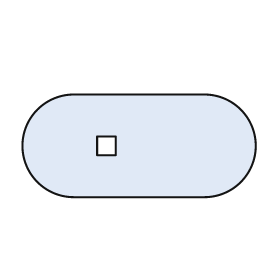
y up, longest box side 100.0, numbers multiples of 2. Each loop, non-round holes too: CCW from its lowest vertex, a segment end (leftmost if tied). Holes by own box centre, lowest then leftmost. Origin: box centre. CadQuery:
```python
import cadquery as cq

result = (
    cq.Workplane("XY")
    .moveTo(-28.0, -22.0)
    .lineTo(28.0, -22.0)
    .threePointArc((50.0, 0.0), (28.0, 22.0))
    .lineTo(-28.0, 22.0)
    .threePointArc((-50.0, 0.0), (-28.0, -22.0))
    .close()
    .moveTo(-18.0, -4.0)
    .lineTo(-10.0, -4.0)
    .lineTo(-10.0, 4.0)
    .lineTo(-18.0, 4.0)
    .close()
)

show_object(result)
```